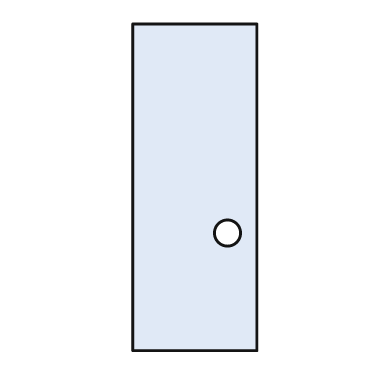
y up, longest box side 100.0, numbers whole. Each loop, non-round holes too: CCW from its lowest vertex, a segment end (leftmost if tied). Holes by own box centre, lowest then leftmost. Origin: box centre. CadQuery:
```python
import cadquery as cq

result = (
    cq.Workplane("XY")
    .moveTo(-19.0, -50.0)
    .lineTo(19.0, -50.0)
    .lineTo(19.0, 50.0)
    .lineTo(-19.0, 50.0)
    .close()
    .moveTo(10.0, -14.0)
    .circle(4.0)
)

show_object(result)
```